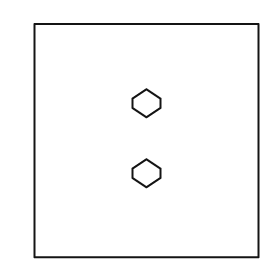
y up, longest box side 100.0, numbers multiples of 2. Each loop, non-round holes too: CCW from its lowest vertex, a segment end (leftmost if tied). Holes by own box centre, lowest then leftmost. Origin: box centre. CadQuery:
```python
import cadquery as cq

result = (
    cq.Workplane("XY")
    .moveTo(-48.0, -50.0)
    .lineTo(48.0, -50.0)
    .lineTo(48.0, 50.0)
    .lineTo(-48.0, 50.0)
    .close()
    .moveTo(0.0, -20.0)
    .lineTo(6.0, -16.0)
    .lineTo(6.0, -12.0)
    .lineTo(0.0, -8.0)
    .lineTo(-6.0, -12.0)
    .lineTo(-6.0, -16.0)
    .close()
    .moveTo(0.0, 10.0)
    .lineTo(6.0, 14.0)
    .lineTo(6.0, 18.0)
    .lineTo(0.0, 22.0)
    .lineTo(-6.0, 18.0)
    .lineTo(-6.0, 14.0)
    .close()
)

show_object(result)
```